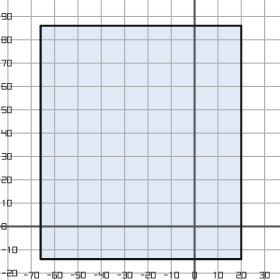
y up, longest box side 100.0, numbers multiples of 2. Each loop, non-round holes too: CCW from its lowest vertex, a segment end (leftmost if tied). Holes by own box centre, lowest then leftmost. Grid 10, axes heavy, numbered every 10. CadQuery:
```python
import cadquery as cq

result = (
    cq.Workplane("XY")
    .moveTo(-66.0, -14.0)
    .lineTo(20.0, -14.0)
    .lineTo(20.0, 86.0)
    .lineTo(-66.0, 86.0)
    .close()
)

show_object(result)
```